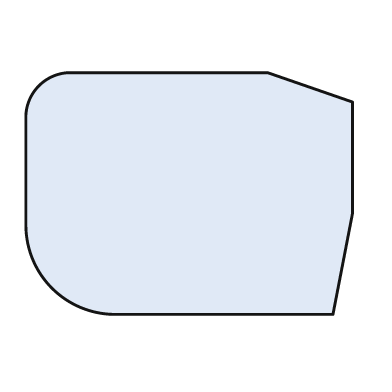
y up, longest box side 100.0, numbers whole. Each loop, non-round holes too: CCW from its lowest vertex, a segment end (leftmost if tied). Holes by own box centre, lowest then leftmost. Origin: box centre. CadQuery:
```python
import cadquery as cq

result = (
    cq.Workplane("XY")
    .moveTo(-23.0, -37.0)
    .lineTo(44.0, -37.0)
    .lineTo(50.0, -6.0)
    .lineTo(50.0, 28.0)
    .lineTo(24.0, 37.0)
    .lineTo(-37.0, 37.0)
    .threePointArc((-46.0, 33.0), (-50.0, 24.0))
    .lineTo(-50.0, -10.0)
    .threePointArc((-42.0, -29.0), (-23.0, -37.0))
    .close()
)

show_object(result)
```